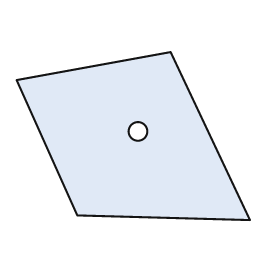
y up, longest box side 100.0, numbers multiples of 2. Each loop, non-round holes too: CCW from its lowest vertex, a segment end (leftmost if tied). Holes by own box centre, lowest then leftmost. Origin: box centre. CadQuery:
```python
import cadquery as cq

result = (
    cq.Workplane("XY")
    .moveTo(50.0, -36.0)
    .lineTo(16.0, 36.0)
    .lineTo(-50.0, 24.0)
    .lineTo(-24.0, -34.0)
    .close()
    .moveTo(2.0, 2.0)
    .circle(4.0)
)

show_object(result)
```